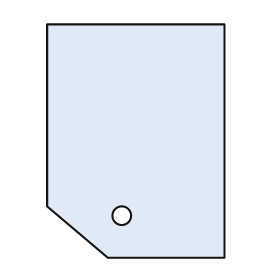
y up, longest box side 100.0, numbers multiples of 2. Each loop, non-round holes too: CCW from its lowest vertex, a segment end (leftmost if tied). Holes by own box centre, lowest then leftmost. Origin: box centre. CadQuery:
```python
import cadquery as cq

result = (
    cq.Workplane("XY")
    .moveTo(-12.0, -50.0)
    .lineTo(38.0, -50.0)
    .lineTo(38.0, 50.0)
    .lineTo(-38.0, 50.0)
    .lineTo(-38.0, -28.0)
    .close()
    .moveTo(-6.0, -32.0)
    .circle(4.0)
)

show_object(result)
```